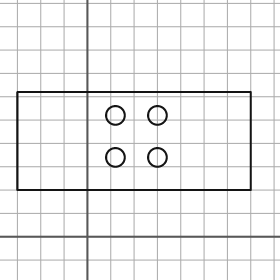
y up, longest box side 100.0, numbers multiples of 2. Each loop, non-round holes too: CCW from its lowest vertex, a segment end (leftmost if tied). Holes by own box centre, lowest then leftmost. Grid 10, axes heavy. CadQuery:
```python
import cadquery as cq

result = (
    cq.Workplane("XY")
    .moveTo(-30.0, 20.0)
    .lineTo(70.0, 20.0)
    .lineTo(70.0, 62.0)
    .lineTo(-30.0, 62.0)
    .close()
    .moveTo(12.0, 34.0)
    .circle(4.0)
    .moveTo(30.0, 34.0)
    .circle(4.0)
    .moveTo(12.0, 52.0)
    .circle(4.0)
    .moveTo(30.0, 52.0)
    .circle(4.0)
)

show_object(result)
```